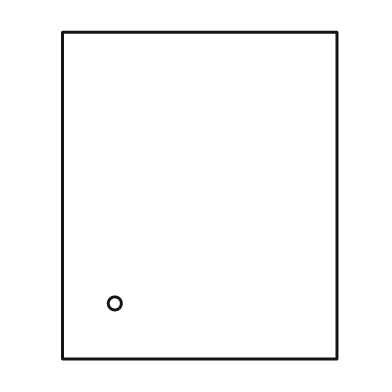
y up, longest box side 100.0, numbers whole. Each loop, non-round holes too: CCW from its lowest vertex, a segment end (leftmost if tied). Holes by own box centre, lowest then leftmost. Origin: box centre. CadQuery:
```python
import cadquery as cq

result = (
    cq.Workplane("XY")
    .moveTo(-42.0, -50.0)
    .lineTo(42.0, -50.0)
    .lineTo(42.0, 50.0)
    .lineTo(-42.0, 50.0)
    .close()
    .moveTo(-26.0, -33.0)
    .circle(2.0)
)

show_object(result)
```